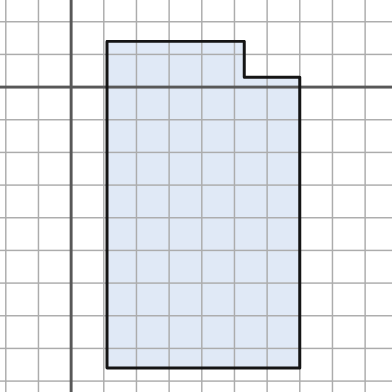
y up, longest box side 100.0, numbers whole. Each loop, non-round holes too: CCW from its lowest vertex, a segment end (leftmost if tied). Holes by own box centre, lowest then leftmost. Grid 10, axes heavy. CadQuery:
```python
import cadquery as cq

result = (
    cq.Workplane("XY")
    .moveTo(11.0, -86.0)
    .lineTo(70.0, -86.0)
    .lineTo(70.0, 3.0)
    .lineTo(53.0, 3.0)
    .lineTo(53.0, 14.0)
    .lineTo(11.0, 14.0)
    .close()
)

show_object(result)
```